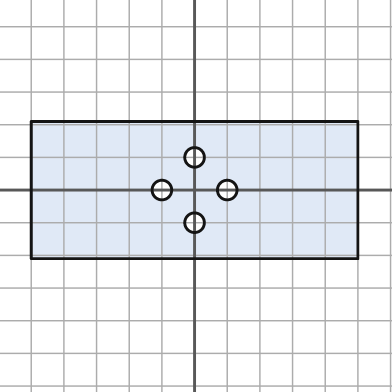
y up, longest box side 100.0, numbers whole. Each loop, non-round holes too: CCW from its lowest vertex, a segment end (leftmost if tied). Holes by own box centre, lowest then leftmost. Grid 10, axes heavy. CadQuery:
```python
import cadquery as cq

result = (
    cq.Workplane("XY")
    .moveTo(-50.0, -21.0)
    .lineTo(50.0, -21.0)
    .lineTo(50.0, 21.0)
    .lineTo(-50.0, 21.0)
    .close()
    .moveTo(0.0, -10.0)
    .circle(3.0)
    .moveTo(-10.0, 0.0)
    .circle(3.0)
    .moveTo(10.0, 0.0)
    .circle(3.0)
    .moveTo(0.0, 10.0)
    .circle(3.0)
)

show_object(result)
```